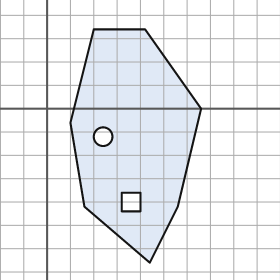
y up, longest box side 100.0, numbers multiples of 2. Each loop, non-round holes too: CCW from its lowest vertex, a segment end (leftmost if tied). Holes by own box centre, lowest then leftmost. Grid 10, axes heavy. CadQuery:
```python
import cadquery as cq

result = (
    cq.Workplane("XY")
    .moveTo(44.0, -66.0)
    .lineTo(56.0, -42.0)
    .lineTo(66.0, 0.0)
    .lineTo(42.0, 34.0)
    .lineTo(20.0, 34.0)
    .lineTo(10.0, -6.0)
    .lineTo(16.0, -42.0)
    .close()
    .moveTo(32.0, -44.0)
    .lineTo(40.0, -44.0)
    .lineTo(40.0, -36.0)
    .lineTo(32.0, -36.0)
    .close()
    .moveTo(24.0, -12.0)
    .circle(4.0)
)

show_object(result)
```